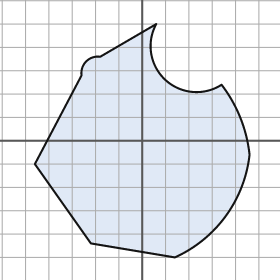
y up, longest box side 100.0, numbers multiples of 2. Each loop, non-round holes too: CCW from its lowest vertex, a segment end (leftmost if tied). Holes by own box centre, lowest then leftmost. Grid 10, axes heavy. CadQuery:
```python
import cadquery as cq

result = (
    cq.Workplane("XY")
    .moveTo(14.0, -50.0)
    .threePointArc((36.0, -32.0), (46.0, -6.0))
    .threePointArc((42.0, 10.0), (34.0, 24.0))
    .threePointArc((10.0, 26.0), (6.0, 50.0))
    .lineTo(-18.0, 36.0)
    .threePointArc((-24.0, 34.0), (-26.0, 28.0))
    .lineTo(-46.0, -10.0)
    .lineTo(-22.0, -44.0)
    .close()
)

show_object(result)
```